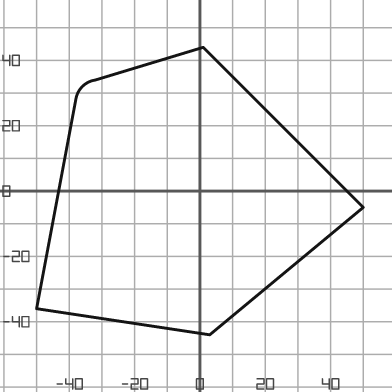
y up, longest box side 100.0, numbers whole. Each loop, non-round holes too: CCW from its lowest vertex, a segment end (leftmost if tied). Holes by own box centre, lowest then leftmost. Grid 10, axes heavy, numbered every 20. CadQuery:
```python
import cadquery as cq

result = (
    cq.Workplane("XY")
    .moveTo(3.0, -44.0)
    .lineTo(50.0, -5.0)
    .lineTo(1.0, 44.0)
    .lineTo(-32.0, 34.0)
    .threePointArc((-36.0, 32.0), (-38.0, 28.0))
    .lineTo(-50.0, -36.0)
    .close()
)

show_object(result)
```